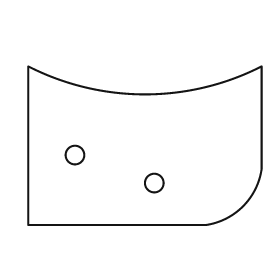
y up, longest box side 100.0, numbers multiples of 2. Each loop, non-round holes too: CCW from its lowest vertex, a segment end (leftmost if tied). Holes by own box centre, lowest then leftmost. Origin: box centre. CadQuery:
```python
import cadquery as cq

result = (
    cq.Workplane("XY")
    .moveTo(-50.0, -34.0)
    .lineTo(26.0, -34.0)
    .threePointArc((42.0, -26.0), (50.0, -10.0))
    .lineTo(50.0, 34.0)
    .threePointArc((0.0, 22.0), (-50.0, 34.0))
    .close()
    .moveTo(4.0, -16.0)
    .circle(4.0)
    .moveTo(-30.0, -4.0)
    .circle(4.0)
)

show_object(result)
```